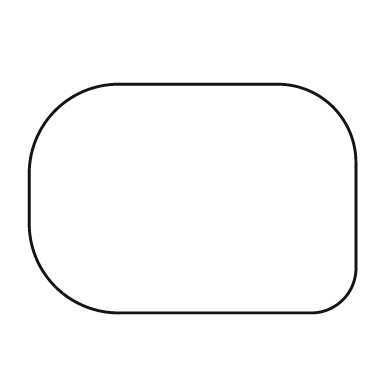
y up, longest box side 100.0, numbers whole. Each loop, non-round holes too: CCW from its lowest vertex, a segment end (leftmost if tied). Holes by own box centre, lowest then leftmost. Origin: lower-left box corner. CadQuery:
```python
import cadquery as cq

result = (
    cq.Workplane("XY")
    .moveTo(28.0, 0.0)
    .lineTo(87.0, 0.0)
    .threePointArc((96.0, 4.0), (100.0, 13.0))
    .lineTo(100.0, 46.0)
    .threePointArc((93.0, 63.0), (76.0, 70.0))
    .lineTo(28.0, 70.0)
    .threePointArc((8.0, 62.0), (0.0, 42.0))
    .lineTo(0.0, 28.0)
    .threePointArc((8.0, 8.0), (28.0, 0.0))
    .close()
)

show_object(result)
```